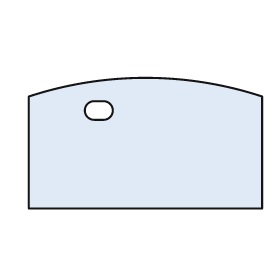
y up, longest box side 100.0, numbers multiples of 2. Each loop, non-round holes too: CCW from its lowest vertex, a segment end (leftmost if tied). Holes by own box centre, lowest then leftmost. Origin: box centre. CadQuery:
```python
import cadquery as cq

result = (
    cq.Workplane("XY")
    .moveTo(-50.0, -28.0)
    .lineTo(50.0, -28.0)
    .lineTo(50.0, 20.0)
    .threePointArc((0.0, 28.0), (-50.0, 20.0))
    .close()
    .moveTo(-22.0, 10.0)
    .lineTo(-18.0, 10.0)
    .threePointArc((-14.0, 14.0), (-18.0, 18.0))
    .lineTo(-22.0, 18.0)
    .threePointArc((-26.0, 14.0), (-22.0, 10.0))
    .close()
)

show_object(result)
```